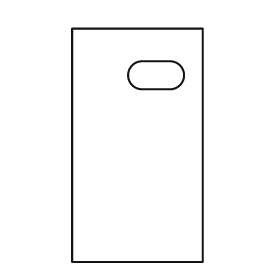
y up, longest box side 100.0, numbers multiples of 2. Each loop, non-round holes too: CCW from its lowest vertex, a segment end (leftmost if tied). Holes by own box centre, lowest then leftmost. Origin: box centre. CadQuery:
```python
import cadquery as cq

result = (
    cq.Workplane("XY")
    .moveTo(-28.0, -50.0)
    .lineTo(28.0, -50.0)
    .lineTo(28.0, 50.0)
    .lineTo(-28.0, 50.0)
    .close()
    .moveTo(2.0, 24.0)
    .lineTo(14.0, 24.0)
    .threePointArc((20.0, 30.0), (14.0, 36.0))
    .lineTo(2.0, 36.0)
    .threePointArc((-4.0, 30.0), (2.0, 24.0))
    .close()
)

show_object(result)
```